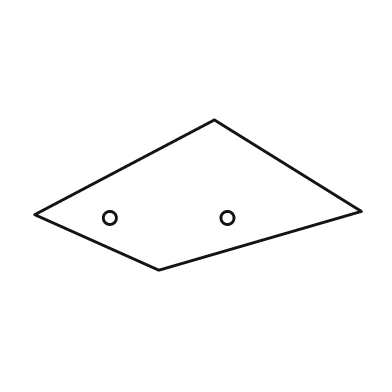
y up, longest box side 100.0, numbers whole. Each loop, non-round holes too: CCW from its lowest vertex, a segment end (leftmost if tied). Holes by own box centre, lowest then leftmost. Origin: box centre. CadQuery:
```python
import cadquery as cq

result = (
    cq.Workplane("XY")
    .moveTo(-12.0, -23.0)
    .lineTo(50.0, -5.0)
    .lineTo(5.0, 23.0)
    .lineTo(-50.0, -6.0)
    .close()
    .moveTo(-27.0, -7.0)
    .circle(2.0)
    .moveTo(9.0, -7.0)
    .circle(2.0)
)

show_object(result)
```